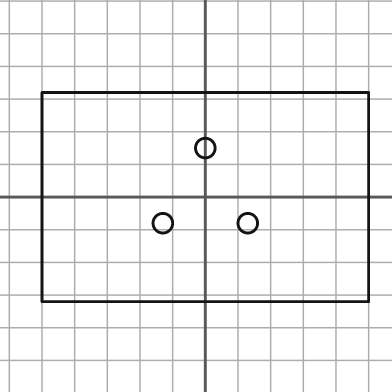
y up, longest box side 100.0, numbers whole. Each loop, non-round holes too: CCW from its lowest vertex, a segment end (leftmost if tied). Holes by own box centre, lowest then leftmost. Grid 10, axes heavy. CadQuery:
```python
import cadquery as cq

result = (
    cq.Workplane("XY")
    .moveTo(-50.0, -32.0)
    .lineTo(50.0, -32.0)
    .lineTo(50.0, 32.0)
    .lineTo(-50.0, 32.0)
    .close()
    .moveTo(-13.0, -8.0)
    .circle(3.0)
    .moveTo(13.0, -8.0)
    .circle(3.0)
    .moveTo(0.0, 15.0)
    .circle(3.0)
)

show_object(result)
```